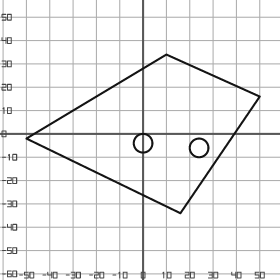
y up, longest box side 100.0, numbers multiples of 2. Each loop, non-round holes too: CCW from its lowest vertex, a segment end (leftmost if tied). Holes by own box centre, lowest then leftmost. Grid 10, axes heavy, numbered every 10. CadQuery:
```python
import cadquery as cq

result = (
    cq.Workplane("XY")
    .moveTo(16.0, -34.0)
    .lineTo(50.0, 16.0)
    .lineTo(10.0, 34.0)
    .lineTo(-50.0, -2.0)
    .close()
    .moveTo(24.0, -6.0)
    .circle(4.0)
    .moveTo(0.0, -4.0)
    .circle(4.0)
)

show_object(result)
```